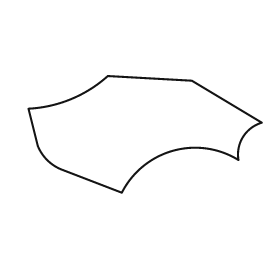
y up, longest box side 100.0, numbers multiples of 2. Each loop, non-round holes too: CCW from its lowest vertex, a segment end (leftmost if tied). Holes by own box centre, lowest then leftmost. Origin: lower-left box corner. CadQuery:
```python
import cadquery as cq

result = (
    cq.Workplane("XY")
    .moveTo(40.0, 0.0)
    .threePointArc((62.0, 18.0), (90.0, 14.0))
    .threePointArc((92.0, 24.0), (100.0, 30.0))
    .lineTo(70.0, 48.0)
    .lineTo(34.0, 50.0)
    .threePointArc((18.0, 40.0), (0.0, 36.0))
    .lineTo(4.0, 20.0)
    .threePointArc((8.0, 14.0), (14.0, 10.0))
    .close()
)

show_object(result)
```